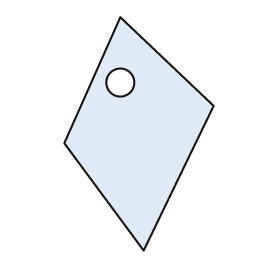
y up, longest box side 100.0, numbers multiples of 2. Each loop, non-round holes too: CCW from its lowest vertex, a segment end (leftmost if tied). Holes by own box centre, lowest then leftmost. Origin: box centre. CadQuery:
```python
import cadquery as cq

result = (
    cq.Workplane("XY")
    .moveTo(2.0, -50.0)
    .lineTo(32.0, 12.0)
    .lineTo(-8.0, 50.0)
    .lineTo(-32.0, -4.0)
    .close()
    .moveTo(-8.0, 22.0)
    .circle(6.0)
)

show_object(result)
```